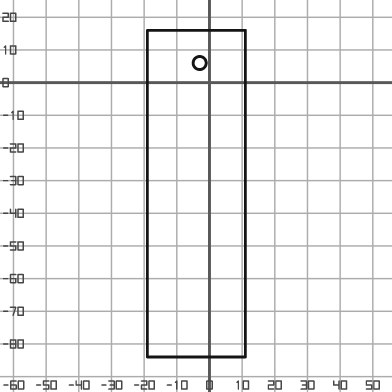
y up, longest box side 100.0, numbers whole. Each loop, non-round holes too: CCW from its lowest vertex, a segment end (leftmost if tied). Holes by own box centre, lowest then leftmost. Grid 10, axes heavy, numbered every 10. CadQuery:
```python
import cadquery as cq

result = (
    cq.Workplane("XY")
    .moveTo(-19.0, -84.0)
    .lineTo(11.0, -84.0)
    .lineTo(11.0, 16.0)
    .lineTo(-19.0, 16.0)
    .close()
    .moveTo(-3.0, 6.0)
    .circle(2.0)
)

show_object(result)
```